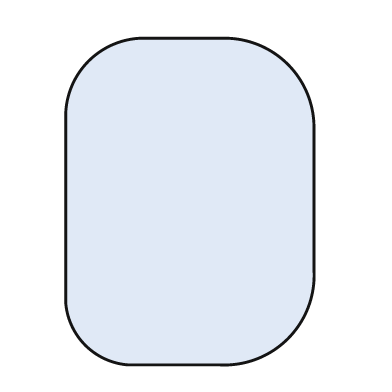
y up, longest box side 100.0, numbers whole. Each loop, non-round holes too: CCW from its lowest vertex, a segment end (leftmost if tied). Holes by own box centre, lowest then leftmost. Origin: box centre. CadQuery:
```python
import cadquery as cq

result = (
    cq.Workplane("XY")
    .moveTo(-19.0, -50.0)
    .lineTo(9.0, -50.0)
    .threePointArc((30.0, -42.0), (38.0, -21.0))
    .lineTo(38.0, 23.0)
    .threePointArc((30.0, 42.0), (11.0, 50.0))
    .lineTo(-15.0, 50.0)
    .threePointArc((-31.0, 43.0), (-38.0, 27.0))
    .lineTo(-38.0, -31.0)
    .threePointArc((-32.0, -44.0), (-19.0, -50.0))
    .close()
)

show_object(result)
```